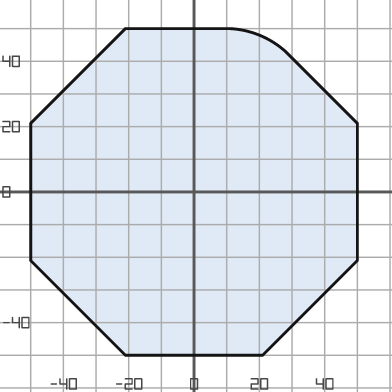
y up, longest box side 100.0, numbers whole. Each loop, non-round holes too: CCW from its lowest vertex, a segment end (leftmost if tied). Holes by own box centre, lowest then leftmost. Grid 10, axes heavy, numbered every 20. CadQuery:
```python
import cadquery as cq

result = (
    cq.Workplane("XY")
    .moveTo(-21.0, -50.0)
    .lineTo(21.0, -50.0)
    .lineTo(50.0, -21.0)
    .lineTo(50.0, 21.0)
    .lineTo(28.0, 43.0)
    .threePointArc((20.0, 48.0), (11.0, 50.0))
    .lineTo(-21.0, 50.0)
    .lineTo(-50.0, 21.0)
    .lineTo(-50.0, -21.0)
    .close()
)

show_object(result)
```